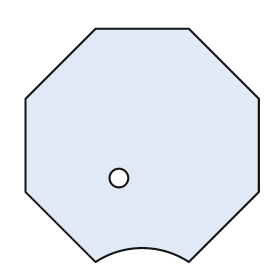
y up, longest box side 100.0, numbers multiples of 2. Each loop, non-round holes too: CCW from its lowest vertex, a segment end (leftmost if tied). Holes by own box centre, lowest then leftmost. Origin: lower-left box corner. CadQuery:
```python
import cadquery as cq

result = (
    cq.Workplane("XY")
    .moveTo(30.0, 0.0)
    .threePointArc((50.0, 6.0), (70.0, 0.0))
    .lineTo(100.0, 30.0)
    .lineTo(100.0, 70.0)
    .lineTo(70.0, 100.0)
    .lineTo(30.0, 100.0)
    .lineTo(0.0, 70.0)
    .lineTo(0.0, 30.0)
    .close()
    .moveTo(40.0, 36.0)
    .circle(4.0)
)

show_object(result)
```